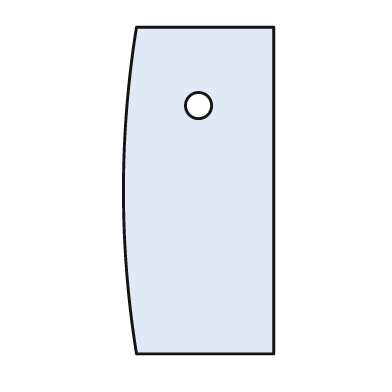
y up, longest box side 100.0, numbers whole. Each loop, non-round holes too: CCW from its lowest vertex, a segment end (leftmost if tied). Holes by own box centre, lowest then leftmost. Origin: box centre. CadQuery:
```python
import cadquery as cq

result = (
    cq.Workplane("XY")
    .moveTo(-19.0, -50.0)
    .lineTo(23.0, -50.0)
    .lineTo(23.0, 50.0)
    .lineTo(-19.0, 50.0)
    .threePointArc((-23.0, 0.0), (-19.0, -50.0))
    .close()
    .moveTo(0.0, 26.0)
    .circle(4.0)
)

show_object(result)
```